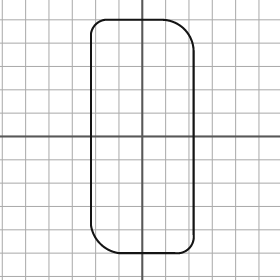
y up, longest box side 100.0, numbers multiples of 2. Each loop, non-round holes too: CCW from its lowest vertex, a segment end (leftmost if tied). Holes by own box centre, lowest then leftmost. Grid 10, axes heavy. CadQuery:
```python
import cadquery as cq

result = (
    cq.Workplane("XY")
    .moveTo(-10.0, -50.0)
    .lineTo(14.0, -50.0)
    .threePointArc((20.0, -48.0), (22.0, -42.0))
    .lineTo(22.0, 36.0)
    .threePointArc((18.0, 46.0), (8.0, 50.0))
    .lineTo(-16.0, 50.0)
    .threePointArc((-20.0, 48.0), (-22.0, 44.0))
    .lineTo(-22.0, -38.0)
    .threePointArc((-18.0, -46.0), (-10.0, -50.0))
    .close()
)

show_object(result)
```